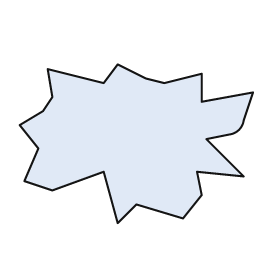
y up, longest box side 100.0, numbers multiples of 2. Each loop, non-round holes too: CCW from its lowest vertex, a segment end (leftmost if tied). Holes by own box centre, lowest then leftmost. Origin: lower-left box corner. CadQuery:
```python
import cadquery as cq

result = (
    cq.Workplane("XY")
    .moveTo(42.0, 0.0)
    .lineTo(50.0, 8.0)
    .lineTo(70.0, 2.0)
    .lineTo(78.0, 12.0)
    .lineTo(76.0, 22.0)
    .lineTo(96.0, 20.0)
    .lineTo(80.0, 36.0)
    .lineTo(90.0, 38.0)
    .threePointArc((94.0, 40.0), (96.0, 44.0))
    .lineTo(100.0, 56.0)
    .lineTo(78.0, 52.0)
    .lineTo(78.0, 64.0)
    .lineTo(62.0, 60.0)
    .lineTo(54.0, 62.0)
    .lineTo(42.0, 68.0)
    .lineTo(36.0, 60.0)
    .lineTo(12.0, 66.0)
    .lineTo(14.0, 54.0)
    .lineTo(10.0, 48.0)
    .lineTo(0.0, 42.0)
    .lineTo(8.0, 32.0)
    .lineTo(2.0, 18.0)
    .lineTo(14.0, 14.0)
    .lineTo(36.0, 22.0)
    .close()
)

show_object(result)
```